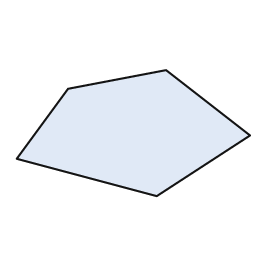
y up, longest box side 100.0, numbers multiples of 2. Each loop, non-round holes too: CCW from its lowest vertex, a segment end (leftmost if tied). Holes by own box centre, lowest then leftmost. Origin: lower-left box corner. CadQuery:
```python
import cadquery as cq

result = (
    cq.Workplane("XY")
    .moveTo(60.0, 0.0)
    .lineTo(100.0, 26.0)
    .lineTo(64.0, 54.0)
    .lineTo(22.0, 46.0)
    .lineTo(0.0, 16.0)
    .close()
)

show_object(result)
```